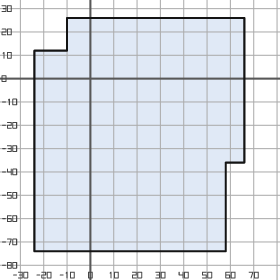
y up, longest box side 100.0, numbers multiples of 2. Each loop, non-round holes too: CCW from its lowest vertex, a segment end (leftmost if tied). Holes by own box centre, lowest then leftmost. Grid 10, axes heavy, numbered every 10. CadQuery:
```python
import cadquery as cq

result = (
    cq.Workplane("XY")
    .moveTo(-24.0, -74.0)
    .lineTo(58.0, -74.0)
    .lineTo(58.0, -36.0)
    .lineTo(66.0, -36.0)
    .lineTo(66.0, 26.0)
    .lineTo(-10.0, 26.0)
    .lineTo(-10.0, 12.0)
    .lineTo(-24.0, 12.0)
    .close()
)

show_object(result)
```